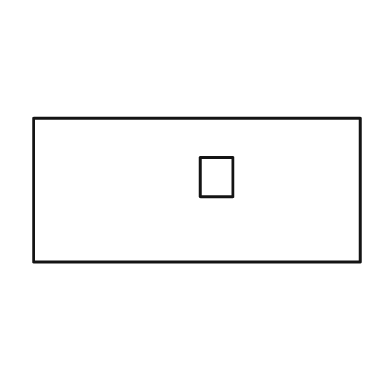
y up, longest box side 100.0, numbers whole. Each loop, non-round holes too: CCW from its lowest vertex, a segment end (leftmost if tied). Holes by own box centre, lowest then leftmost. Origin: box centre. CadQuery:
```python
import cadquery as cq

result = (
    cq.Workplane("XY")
    .moveTo(-50.0, -22.0)
    .lineTo(50.0, -22.0)
    .lineTo(50.0, 22.0)
    .lineTo(-50.0, 22.0)
    .close()
    .moveTo(1.0, -2.0)
    .lineTo(11.0, -2.0)
    .lineTo(11.0, 10.0)
    .lineTo(1.0, 10.0)
    .close()
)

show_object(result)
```